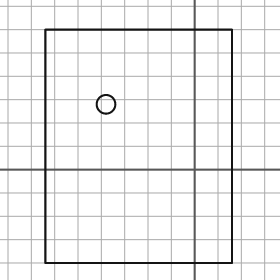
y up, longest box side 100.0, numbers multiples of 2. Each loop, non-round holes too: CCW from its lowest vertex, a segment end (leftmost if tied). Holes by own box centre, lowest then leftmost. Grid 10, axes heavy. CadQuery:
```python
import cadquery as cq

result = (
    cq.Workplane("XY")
    .moveTo(-64.0, -40.0)
    .lineTo(16.0, -40.0)
    .lineTo(16.0, 60.0)
    .lineTo(-64.0, 60.0)
    .close()
    .moveTo(-38.0, 28.0)
    .circle(4.0)
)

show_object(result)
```